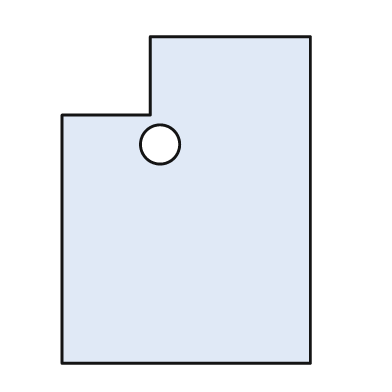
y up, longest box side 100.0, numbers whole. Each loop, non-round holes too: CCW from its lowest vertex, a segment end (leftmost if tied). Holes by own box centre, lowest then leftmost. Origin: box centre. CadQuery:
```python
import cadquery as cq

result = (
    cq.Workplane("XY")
    .moveTo(-38.0, -50.0)
    .lineTo(38.0, -50.0)
    .lineTo(38.0, 50.0)
    .lineTo(-11.0, 50.0)
    .lineTo(-11.0, 26.0)
    .lineTo(-38.0, 26.0)
    .close()
    .moveTo(-8.0, 17.0)
    .circle(6.0)
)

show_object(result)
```